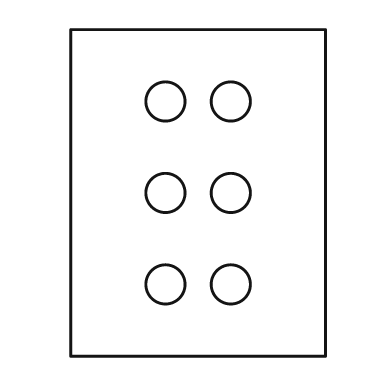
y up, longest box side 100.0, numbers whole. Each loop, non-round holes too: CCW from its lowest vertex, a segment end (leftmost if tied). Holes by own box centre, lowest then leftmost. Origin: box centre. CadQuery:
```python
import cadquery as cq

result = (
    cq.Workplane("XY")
    .moveTo(-39.0, -50.0)
    .lineTo(39.0, -50.0)
    .lineTo(39.0, 50.0)
    .lineTo(-39.0, 50.0)
    .close()
    .moveTo(-10.0, -28.0)
    .circle(6.0)
    .moveTo(10.0, -28.0)
    .circle(6.0)
    .moveTo(-10.0, 0.0)
    .circle(6.0)
    .moveTo(10.0, 0.0)
    .circle(6.0)
    .moveTo(-10.0, 28.0)
    .circle(6.0)
    .moveTo(10.0, 28.0)
    .circle(6.0)
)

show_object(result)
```